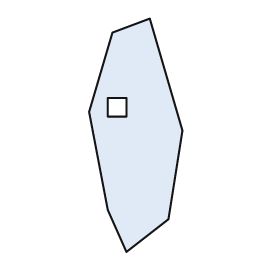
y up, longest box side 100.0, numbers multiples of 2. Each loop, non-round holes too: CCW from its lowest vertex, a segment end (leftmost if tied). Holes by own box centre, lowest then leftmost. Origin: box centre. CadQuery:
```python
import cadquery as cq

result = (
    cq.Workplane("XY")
    .moveTo(-4.0, -50.0)
    .lineTo(14.0, -36.0)
    .lineTo(20.0, 2.0)
    .lineTo(6.0, 50.0)
    .lineTo(-10.0, 44.0)
    .lineTo(-20.0, 10.0)
    .lineTo(-12.0, -32.0)
    .close()
    .moveTo(-12.0, 8.0)
    .lineTo(-4.0, 8.0)
    .lineTo(-4.0, 16.0)
    .lineTo(-12.0, 16.0)
    .close()
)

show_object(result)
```